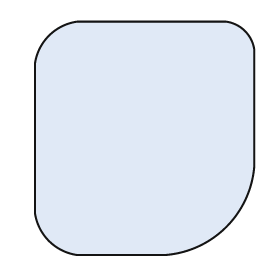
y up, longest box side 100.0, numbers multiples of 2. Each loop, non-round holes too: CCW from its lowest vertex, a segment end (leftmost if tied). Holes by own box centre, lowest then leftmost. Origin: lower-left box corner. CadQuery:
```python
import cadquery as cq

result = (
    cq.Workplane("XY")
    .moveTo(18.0, 0.0)
    .lineTo(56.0, 0.0)
    .threePointArc((82.0, 12.0), (94.0, 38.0))
    .lineTo(94.0, 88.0)
    .threePointArc((90.0, 96.0), (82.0, 100.0))
    .lineTo(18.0, 100.0)
    .threePointArc((6.0, 94.0), (0.0, 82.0))
    .lineTo(0.0, 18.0)
    .threePointArc((6.0, 6.0), (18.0, 0.0))
    .close()
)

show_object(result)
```